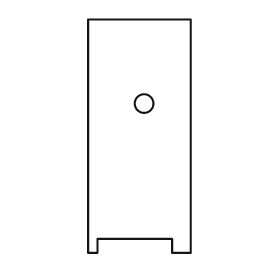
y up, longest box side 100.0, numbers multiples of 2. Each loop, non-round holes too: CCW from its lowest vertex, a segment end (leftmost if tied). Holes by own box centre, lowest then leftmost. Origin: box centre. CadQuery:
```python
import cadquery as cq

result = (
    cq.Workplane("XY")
    .moveTo(-22.0, -50.0)
    .lineTo(-18.0, -50.0)
    .lineTo(-18.0, -44.0)
    .lineTo(14.0, -44.0)
    .lineTo(14.0, -50.0)
    .lineTo(22.0, -50.0)
    .lineTo(22.0, 50.0)
    .lineTo(-22.0, 50.0)
    .close()
    .moveTo(2.0, 14.0)
    .circle(4.0)
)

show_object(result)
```